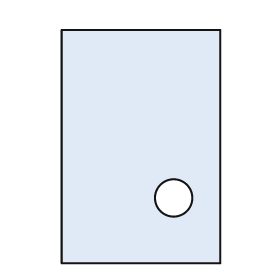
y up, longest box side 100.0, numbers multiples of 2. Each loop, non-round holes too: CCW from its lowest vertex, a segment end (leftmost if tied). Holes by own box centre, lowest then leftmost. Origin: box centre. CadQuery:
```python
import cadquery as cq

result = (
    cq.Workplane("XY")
    .moveTo(-34.0, -50.0)
    .lineTo(34.0, -50.0)
    .lineTo(34.0, 50.0)
    .lineTo(-34.0, 50.0)
    .close()
    .moveTo(14.0, -22.0)
    .circle(8.0)
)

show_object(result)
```